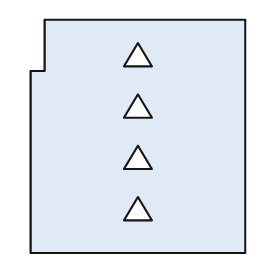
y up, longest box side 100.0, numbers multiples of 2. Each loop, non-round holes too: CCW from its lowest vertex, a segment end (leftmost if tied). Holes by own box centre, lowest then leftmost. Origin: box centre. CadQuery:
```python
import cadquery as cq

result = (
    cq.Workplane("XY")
    .moveTo(-46.0, -50.0)
    .lineTo(46.0, -50.0)
    .lineTo(46.0, 50.0)
    .lineTo(-40.0, 50.0)
    .lineTo(-40.0, 28.0)
    .lineTo(-46.0, 28.0)
    .close()
    .moveTo(-6.0, -36.0)
    .lineTo(6.0, -36.0)
    .lineTo(0.0, -26.0)
    .close()
    .moveTo(-6.0, -14.0)
    .lineTo(6.0, -14.0)
    .lineTo(0.0, -4.0)
    .close()
    .moveTo(-6.0, 8.0)
    .lineTo(6.0, 8.0)
    .lineTo(0.0, 18.0)
    .close()
    .moveTo(-6.0, 30.0)
    .lineTo(6.0, 30.0)
    .lineTo(0.0, 40.0)
    .close()
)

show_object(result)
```